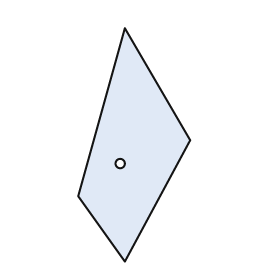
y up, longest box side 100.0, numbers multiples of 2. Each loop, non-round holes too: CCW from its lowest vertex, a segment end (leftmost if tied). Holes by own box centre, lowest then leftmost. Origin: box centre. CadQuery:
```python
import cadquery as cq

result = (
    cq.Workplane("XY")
    .moveTo(-4.0, -50.0)
    .lineTo(24.0, 2.0)
    .lineTo(-4.0, 50.0)
    .lineTo(-24.0, -22.0)
    .close()
    .moveTo(-6.0, -8.0)
    .circle(2.0)
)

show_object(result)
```